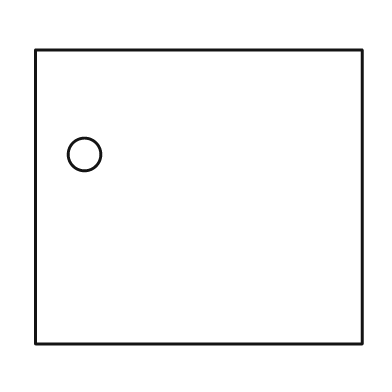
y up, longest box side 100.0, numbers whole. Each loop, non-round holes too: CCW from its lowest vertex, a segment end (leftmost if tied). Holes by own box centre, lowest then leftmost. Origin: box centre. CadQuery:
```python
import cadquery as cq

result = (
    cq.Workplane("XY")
    .moveTo(-50.0, -45.0)
    .lineTo(50.0, -45.0)
    .lineTo(50.0, 45.0)
    .lineTo(-50.0, 45.0)
    .close()
    .moveTo(-35.0, 13.0)
    .circle(5.0)
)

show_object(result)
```